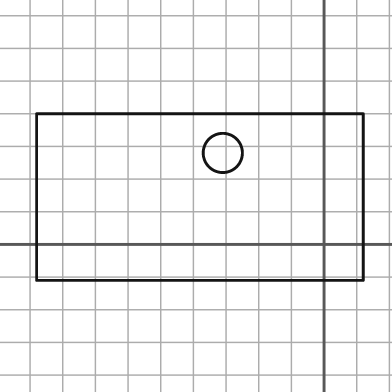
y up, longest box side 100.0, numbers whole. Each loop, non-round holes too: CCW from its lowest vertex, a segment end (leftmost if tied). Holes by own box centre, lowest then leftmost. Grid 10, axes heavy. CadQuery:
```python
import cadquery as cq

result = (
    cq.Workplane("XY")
    .moveTo(-88.0, -11.0)
    .lineTo(12.0, -11.0)
    .lineTo(12.0, 40.0)
    .lineTo(-88.0, 40.0)
    .close()
    .moveTo(-31.0, 28.0)
    .circle(6.0)
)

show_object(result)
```